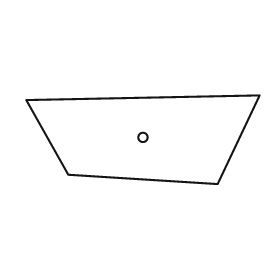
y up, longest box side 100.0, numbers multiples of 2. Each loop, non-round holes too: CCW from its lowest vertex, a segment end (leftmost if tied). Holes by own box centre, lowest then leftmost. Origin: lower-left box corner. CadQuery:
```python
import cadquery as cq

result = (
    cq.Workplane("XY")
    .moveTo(82.0, 0.0)
    .lineTo(100.0, 38.0)
    .lineTo(0.0, 36.0)
    .lineTo(18.0, 4.0)
    .close()
    .moveTo(50.0, 20.0)
    .circle(2.0)
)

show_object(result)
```